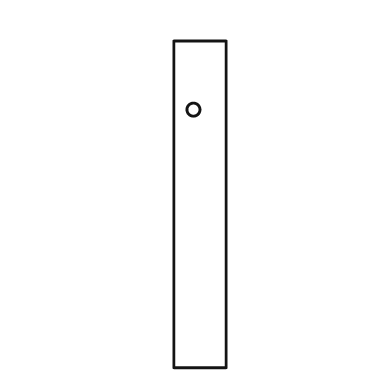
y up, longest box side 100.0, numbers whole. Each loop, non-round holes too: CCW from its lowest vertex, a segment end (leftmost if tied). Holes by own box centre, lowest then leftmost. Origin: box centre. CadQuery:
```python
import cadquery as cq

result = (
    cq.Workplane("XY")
    .moveTo(-8.0, -50.0)
    .lineTo(8.0, -50.0)
    .lineTo(8.0, 50.0)
    .lineTo(-8.0, 50.0)
    .close()
    .moveTo(-2.0, 29.0)
    .circle(2.0)
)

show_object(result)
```